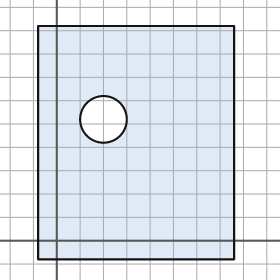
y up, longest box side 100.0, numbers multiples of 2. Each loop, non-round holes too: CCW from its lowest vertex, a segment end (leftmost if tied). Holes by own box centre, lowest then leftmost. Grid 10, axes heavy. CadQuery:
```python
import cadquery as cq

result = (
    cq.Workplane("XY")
    .moveTo(-8.0, -8.0)
    .lineTo(76.0, -8.0)
    .lineTo(76.0, 92.0)
    .lineTo(-8.0, 92.0)
    .close()
    .moveTo(20.0, 52.0)
    .circle(10.0)
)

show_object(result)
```